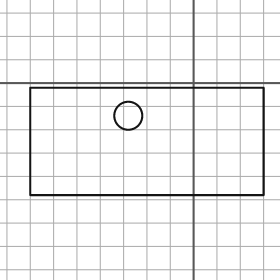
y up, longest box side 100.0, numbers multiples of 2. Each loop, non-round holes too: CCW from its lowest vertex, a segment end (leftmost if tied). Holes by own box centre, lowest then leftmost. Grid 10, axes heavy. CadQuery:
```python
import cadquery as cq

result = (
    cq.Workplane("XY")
    .moveTo(-70.0, -48.0)
    .lineTo(30.0, -48.0)
    .lineTo(30.0, -2.0)
    .lineTo(-70.0, -2.0)
    .close()
    .moveTo(-28.0, -14.0)
    .circle(6.0)
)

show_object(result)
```